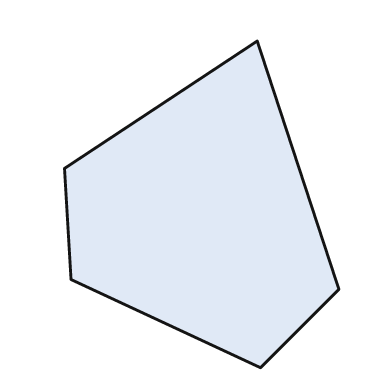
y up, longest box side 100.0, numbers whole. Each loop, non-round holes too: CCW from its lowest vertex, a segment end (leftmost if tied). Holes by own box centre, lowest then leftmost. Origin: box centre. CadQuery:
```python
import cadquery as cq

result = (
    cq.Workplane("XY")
    .moveTo(18.0, -50.0)
    .lineTo(42.0, -26.0)
    .lineTo(17.0, 50.0)
    .lineTo(-42.0, 11.0)
    .lineTo(-40.0, -23.0)
    .close()
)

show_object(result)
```